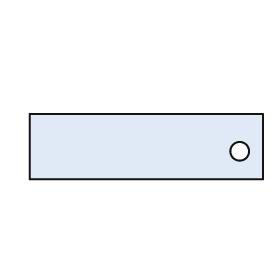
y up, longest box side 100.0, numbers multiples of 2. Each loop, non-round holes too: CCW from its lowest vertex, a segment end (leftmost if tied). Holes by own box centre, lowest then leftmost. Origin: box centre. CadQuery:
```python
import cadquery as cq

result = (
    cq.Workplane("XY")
    .moveTo(-50.0, -14.0)
    .lineTo(50.0, -14.0)
    .lineTo(50.0, 14.0)
    .lineTo(-50.0, 14.0)
    .close()
    .moveTo(40.0, -2.0)
    .circle(4.0)
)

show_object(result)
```